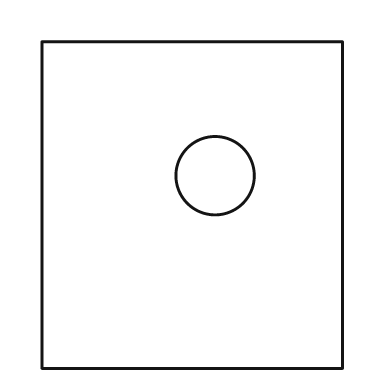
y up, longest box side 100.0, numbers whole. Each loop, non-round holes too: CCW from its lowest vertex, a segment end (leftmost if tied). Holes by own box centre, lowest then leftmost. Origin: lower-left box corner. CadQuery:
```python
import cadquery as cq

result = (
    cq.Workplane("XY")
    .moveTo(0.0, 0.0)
    .lineTo(92.0, 0.0)
    .lineTo(92.0, 100.0)
    .lineTo(0.0, 100.0)
    .close()
    .moveTo(53.0, 59.0)
    .circle(12.0)
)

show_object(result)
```